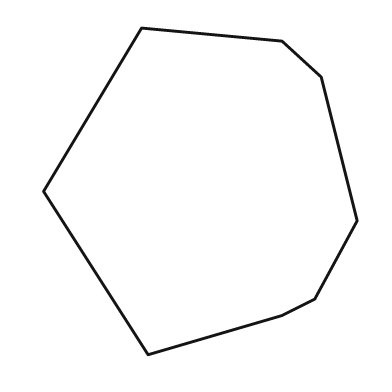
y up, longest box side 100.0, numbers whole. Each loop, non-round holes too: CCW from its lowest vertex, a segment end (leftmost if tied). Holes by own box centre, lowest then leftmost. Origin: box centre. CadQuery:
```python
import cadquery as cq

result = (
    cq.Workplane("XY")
    .moveTo(-16.0, -50.0)
    .lineTo(25.0, -38.0)
    .lineTo(35.0, -33.0)
    .lineTo(48.0, -9.0)
    .lineTo(37.0, 35.0)
    .lineTo(25.0, 46.0)
    .lineTo(-18.0, 50.0)
    .lineTo(-48.0, 0.0)
    .close()
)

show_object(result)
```